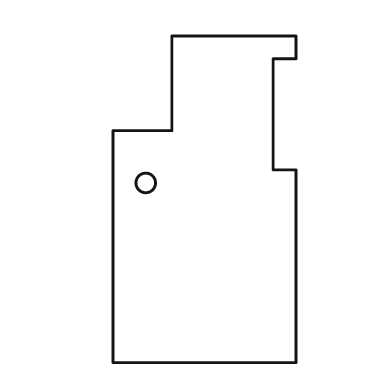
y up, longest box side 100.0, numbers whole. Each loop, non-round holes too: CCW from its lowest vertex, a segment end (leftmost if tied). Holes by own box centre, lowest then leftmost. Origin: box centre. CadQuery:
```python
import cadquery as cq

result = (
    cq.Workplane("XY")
    .moveTo(-28.0, -50.0)
    .lineTo(28.0, -50.0)
    .lineTo(28.0, 9.0)
    .lineTo(21.0, 9.0)
    .lineTo(21.0, 43.0)
    .lineTo(28.0, 43.0)
    .lineTo(28.0, 50.0)
    .lineTo(-10.0, 50.0)
    .lineTo(-10.0, 21.0)
    .lineTo(-28.0, 21.0)
    .close()
    .moveTo(-18.0, 5.0)
    .circle(3.0)
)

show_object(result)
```